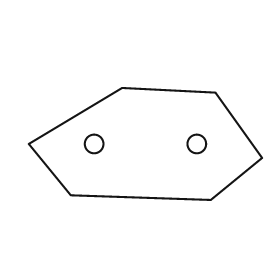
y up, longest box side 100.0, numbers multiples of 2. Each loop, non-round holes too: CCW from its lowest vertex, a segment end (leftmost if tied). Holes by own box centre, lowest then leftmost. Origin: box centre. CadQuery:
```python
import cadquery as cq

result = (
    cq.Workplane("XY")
    .moveTo(28.0, -24.0)
    .lineTo(50.0, -6.0)
    .lineTo(30.0, 22.0)
    .lineTo(-10.0, 24.0)
    .lineTo(-50.0, 0.0)
    .lineTo(-32.0, -22.0)
    .close()
    .moveTo(-22.0, 0.0)
    .circle(4.0)
    .moveTo(22.0, 0.0)
    .circle(4.0)
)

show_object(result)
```